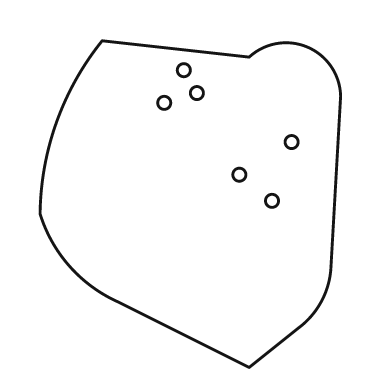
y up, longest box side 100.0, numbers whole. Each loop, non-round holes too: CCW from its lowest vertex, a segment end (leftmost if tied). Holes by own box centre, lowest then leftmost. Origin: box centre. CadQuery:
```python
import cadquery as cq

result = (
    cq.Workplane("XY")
    .moveTo(18.0, -50.0)
    .lineTo(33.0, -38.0)
    .threePointArc((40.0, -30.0), (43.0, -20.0))
    .lineTo(46.0, 33.0)
    .threePointArc((36.0, 48.0), (18.0, 45.0))
    .lineTo(-27.0, 50.0)
    .threePointArc((-41.0, 25.0), (-46.0, -3.0))
    .threePointArc((-37.0, -19.0), (-22.0, -30.0))
    .close()
    .moveTo(25.0, 1.0)
    .circle(2.0)
    .moveTo(15.0, 9.0)
    .circle(2.0)
    .moveTo(31.0, 19.0)
    .circle(2.0)
    .moveTo(-8.0, 31.0)
    .circle(2.0)
    .moveTo(2.0, 34.0)
    .circle(2.0)
    .moveTo(-2.0, 41.0)
    .circle(2.0)
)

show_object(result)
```